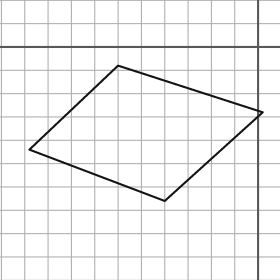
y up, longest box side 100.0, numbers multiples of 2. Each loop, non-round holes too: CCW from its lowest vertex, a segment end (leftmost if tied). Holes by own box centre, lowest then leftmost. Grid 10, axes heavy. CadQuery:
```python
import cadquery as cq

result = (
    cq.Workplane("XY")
    .moveTo(-40.0, -66.0)
    .lineTo(2.0, -28.0)
    .lineTo(-60.0, -8.0)
    .lineTo(-98.0, -44.0)
    .close()
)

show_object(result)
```